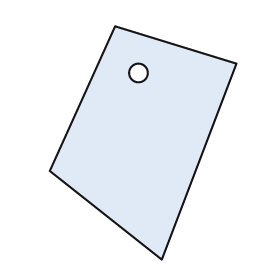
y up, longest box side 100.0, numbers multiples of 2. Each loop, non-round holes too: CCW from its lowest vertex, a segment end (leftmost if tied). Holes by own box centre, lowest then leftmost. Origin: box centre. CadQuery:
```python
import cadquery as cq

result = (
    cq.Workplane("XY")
    .moveTo(8.0, -50.0)
    .lineTo(40.0, 34.0)
    .lineTo(-12.0, 50.0)
    .lineTo(-40.0, -12.0)
    .close()
    .moveTo(-2.0, 30.0)
    .circle(4.0)
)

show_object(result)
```